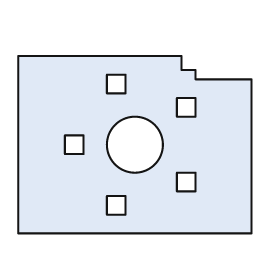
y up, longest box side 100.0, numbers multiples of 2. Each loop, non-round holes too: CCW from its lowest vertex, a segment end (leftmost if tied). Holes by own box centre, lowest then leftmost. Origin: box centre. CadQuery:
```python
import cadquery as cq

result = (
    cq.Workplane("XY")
    .moveTo(-50.0, -38.0)
    .lineTo(50.0, -38.0)
    .lineTo(50.0, 28.0)
    .lineTo(26.0, 28.0)
    .lineTo(26.0, 32.0)
    .lineTo(20.0, 32.0)
    .lineTo(20.0, 38.0)
    .lineTo(-50.0, 38.0)
    .close()
    .moveTo(-12.0, -30.0)
    .lineTo(-4.0, -30.0)
    .lineTo(-4.0, -22.0)
    .lineTo(-12.0, -22.0)
    .close()
    .moveTo(18.0, -20.0)
    .lineTo(26.0, -20.0)
    .lineTo(26.0, -12.0)
    .lineTo(18.0, -12.0)
    .close()
    .moveTo(-30.0, -4.0)
    .lineTo(-22.0, -4.0)
    .lineTo(-22.0, 4.0)
    .lineTo(-30.0, 4.0)
    .close()
    .moveTo(0.0, 0.0)
    .circle(12.0)
    .moveTo(18.0, 12.0)
    .lineTo(26.0, 12.0)
    .lineTo(26.0, 20.0)
    .lineTo(18.0, 20.0)
    .close()
    .moveTo(-12.0, 22.0)
    .lineTo(-4.0, 22.0)
    .lineTo(-4.0, 30.0)
    .lineTo(-12.0, 30.0)
    .close()
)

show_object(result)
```